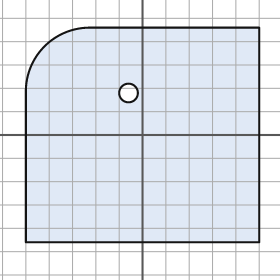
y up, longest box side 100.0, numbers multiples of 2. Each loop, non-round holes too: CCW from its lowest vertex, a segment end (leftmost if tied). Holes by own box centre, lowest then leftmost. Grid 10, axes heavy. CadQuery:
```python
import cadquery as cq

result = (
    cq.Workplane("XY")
    .moveTo(-50.0, -46.0)
    .lineTo(50.0, -46.0)
    .lineTo(50.0, 46.0)
    .lineTo(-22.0, 46.0)
    .threePointArc((-42.0, 38.0), (-50.0, 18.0))
    .close()
    .moveTo(-6.0, 18.0)
    .circle(4.0)
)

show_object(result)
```